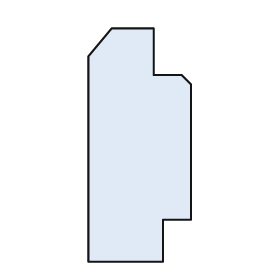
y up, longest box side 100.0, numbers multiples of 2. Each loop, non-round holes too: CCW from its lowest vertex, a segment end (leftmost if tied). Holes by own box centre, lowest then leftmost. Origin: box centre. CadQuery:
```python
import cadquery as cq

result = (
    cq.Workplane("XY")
    .moveTo(-22.0, -50.0)
    .lineTo(10.0, -50.0)
    .lineTo(10.0, -32.0)
    .lineTo(22.0, -32.0)
    .lineTo(22.0, 26.0)
    .lineTo(18.0, 30.0)
    .lineTo(6.0, 30.0)
    .lineTo(6.0, 50.0)
    .lineTo(-12.0, 50.0)
    .lineTo(-22.0, 38.0)
    .close()
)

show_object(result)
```